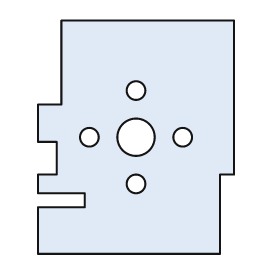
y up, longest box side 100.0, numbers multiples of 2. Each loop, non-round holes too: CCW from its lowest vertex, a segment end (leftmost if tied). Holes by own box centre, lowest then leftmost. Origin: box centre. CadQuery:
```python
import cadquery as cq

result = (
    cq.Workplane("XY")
    .moveTo(-42.0, -50.0)
    .lineTo(36.0, -50.0)
    .lineTo(36.0, -16.0)
    .lineTo(42.0, -16.0)
    .lineTo(42.0, 50.0)
    .lineTo(-32.0, 50.0)
    .lineTo(-32.0, 14.0)
    .lineTo(-42.0, 14.0)
    .lineTo(-42.0, -2.0)
    .lineTo(-34.0, -2.0)
    .lineTo(-34.0, -16.0)
    .lineTo(-42.0, -16.0)
    .lineTo(-42.0, -24.0)
    .lineTo(-22.0, -24.0)
    .lineTo(-22.0, -30.0)
    .lineTo(-42.0, -30.0)
    .close()
    .moveTo(0.0, -20.0)
    .circle(4.0)
    .moveTo(-20.0, 0.0)
    .circle(4.0)
    .moveTo(0.0, 0.0)
    .circle(8.0)
    .moveTo(20.0, 0.0)
    .circle(4.0)
    .moveTo(0.0, 20.0)
    .circle(4.0)
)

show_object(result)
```